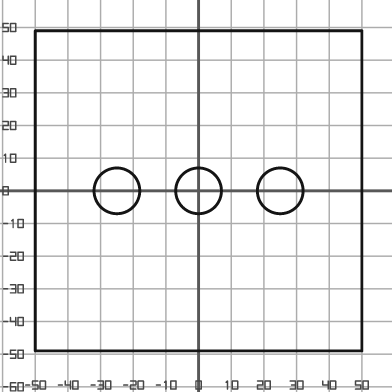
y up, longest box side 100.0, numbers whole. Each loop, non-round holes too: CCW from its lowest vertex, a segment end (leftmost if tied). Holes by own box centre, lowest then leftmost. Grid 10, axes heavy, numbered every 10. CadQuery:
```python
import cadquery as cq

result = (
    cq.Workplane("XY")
    .moveTo(-50.0, -49.0)
    .lineTo(50.0, -49.0)
    .lineTo(50.0, 49.0)
    .lineTo(-50.0, 49.0)
    .close()
    .moveTo(-25.0, 0.0)
    .circle(7.0)
    .moveTo(0.0, 0.0)
    .circle(7.0)
    .moveTo(25.0, 0.0)
    .circle(7.0)
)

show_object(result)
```